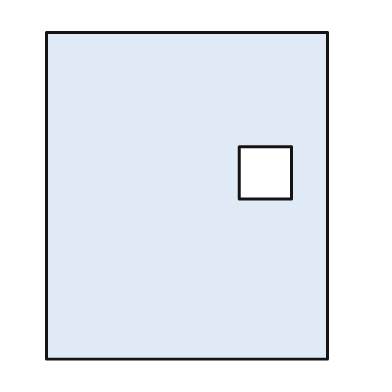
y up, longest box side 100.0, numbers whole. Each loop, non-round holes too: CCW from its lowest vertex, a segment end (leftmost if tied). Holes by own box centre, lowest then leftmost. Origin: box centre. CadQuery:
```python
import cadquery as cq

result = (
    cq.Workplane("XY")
    .moveTo(-43.0, -50.0)
    .lineTo(43.0, -50.0)
    .lineTo(43.0, 50.0)
    .lineTo(-43.0, 50.0)
    .close()
    .moveTo(16.0, -1.0)
    .lineTo(32.0, -1.0)
    .lineTo(32.0, 15.0)
    .lineTo(16.0, 15.0)
    .close()
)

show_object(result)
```